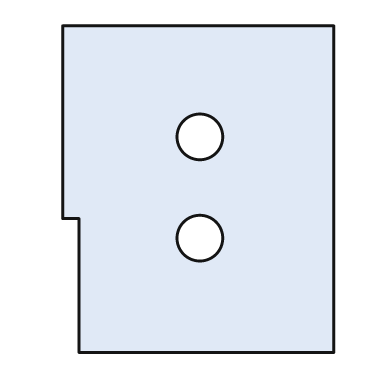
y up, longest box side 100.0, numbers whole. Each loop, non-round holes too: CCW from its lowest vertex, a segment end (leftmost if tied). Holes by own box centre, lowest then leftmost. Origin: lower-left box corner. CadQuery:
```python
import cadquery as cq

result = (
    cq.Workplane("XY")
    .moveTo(5.0, 0.0)
    .lineTo(83.0, 0.0)
    .lineTo(83.0, 100.0)
    .lineTo(0.0, 100.0)
    .lineTo(0.0, 41.0)
    .lineTo(5.0, 41.0)
    .close()
    .moveTo(42.0, 35.0)
    .circle(7.0)
    .moveTo(42.0, 66.0)
    .circle(7.0)
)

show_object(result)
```